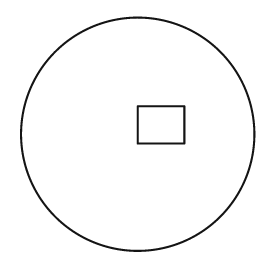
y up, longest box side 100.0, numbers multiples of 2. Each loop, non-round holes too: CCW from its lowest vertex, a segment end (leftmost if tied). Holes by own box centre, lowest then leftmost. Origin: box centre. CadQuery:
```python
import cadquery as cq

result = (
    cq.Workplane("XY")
    .moveTo(0.0, 0.0)
    .circle(50.0)
    .moveTo(0.0, -4.0)
    .lineTo(20.0, -4.0)
    .lineTo(20.0, 12.0)
    .lineTo(0.0, 12.0)
    .close()
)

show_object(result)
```